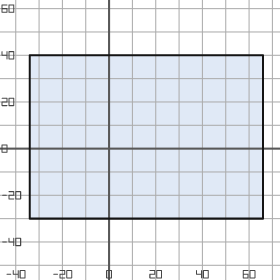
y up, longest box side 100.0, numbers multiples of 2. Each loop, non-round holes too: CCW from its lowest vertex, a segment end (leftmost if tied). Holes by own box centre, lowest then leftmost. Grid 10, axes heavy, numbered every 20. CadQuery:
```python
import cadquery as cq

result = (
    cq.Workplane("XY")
    .moveTo(-34.0, -30.0)
    .lineTo(66.0, -30.0)
    .lineTo(66.0, 40.0)
    .lineTo(-34.0, 40.0)
    .close()
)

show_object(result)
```